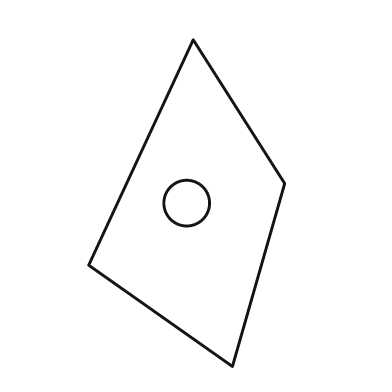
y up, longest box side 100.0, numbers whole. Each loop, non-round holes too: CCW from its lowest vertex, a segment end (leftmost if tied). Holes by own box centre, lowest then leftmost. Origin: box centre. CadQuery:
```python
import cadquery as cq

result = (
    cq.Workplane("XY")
    .moveTo(14.0, -50.0)
    .lineTo(30.0, 6.0)
    .lineTo(2.0, 50.0)
    .lineTo(-30.0, -19.0)
    .close()
    .moveTo(0.0, 0.0)
    .circle(7.0)
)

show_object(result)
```